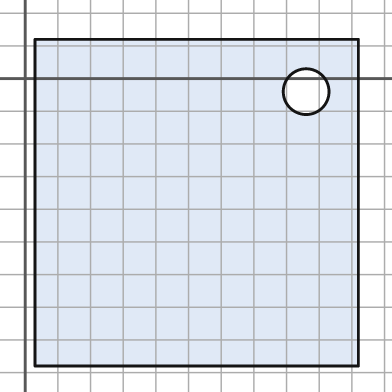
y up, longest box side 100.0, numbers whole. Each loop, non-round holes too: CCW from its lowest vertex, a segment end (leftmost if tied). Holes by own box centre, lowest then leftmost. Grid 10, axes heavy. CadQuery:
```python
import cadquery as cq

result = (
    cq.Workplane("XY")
    .moveTo(3.0, -88.0)
    .lineTo(102.0, -88.0)
    .lineTo(102.0, 12.0)
    .lineTo(3.0, 12.0)
    .close()
    .moveTo(86.0, -4.0)
    .circle(7.0)
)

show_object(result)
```